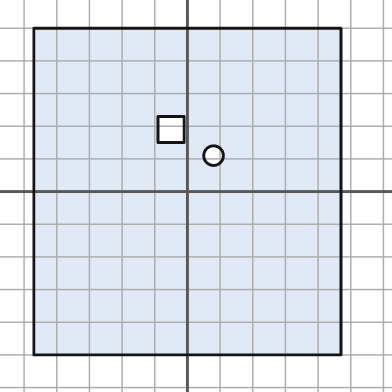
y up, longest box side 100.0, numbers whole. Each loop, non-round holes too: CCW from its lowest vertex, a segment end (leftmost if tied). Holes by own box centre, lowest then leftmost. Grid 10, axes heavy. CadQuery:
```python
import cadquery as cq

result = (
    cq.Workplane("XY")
    .moveTo(-47.0, -50.0)
    .lineTo(47.0, -50.0)
    .lineTo(47.0, 50.0)
    .lineTo(-47.0, 50.0)
    .close()
    .moveTo(8.0, 11.0)
    .circle(3.0)
    .moveTo(-9.0, 15.0)
    .lineTo(-1.0, 15.0)
    .lineTo(-1.0, 23.0)
    .lineTo(-9.0, 23.0)
    .close()
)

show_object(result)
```